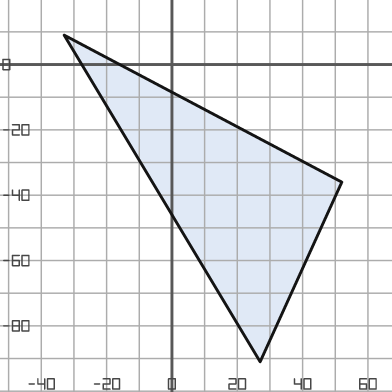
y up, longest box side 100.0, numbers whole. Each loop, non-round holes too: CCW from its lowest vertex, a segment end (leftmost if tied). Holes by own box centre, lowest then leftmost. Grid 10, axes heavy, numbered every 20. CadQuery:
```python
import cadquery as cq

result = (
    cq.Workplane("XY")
    .moveTo(27.0, -91.0)
    .lineTo(52.0, -36.0)
    .lineTo(-33.0, 9.0)
    .close()
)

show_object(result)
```